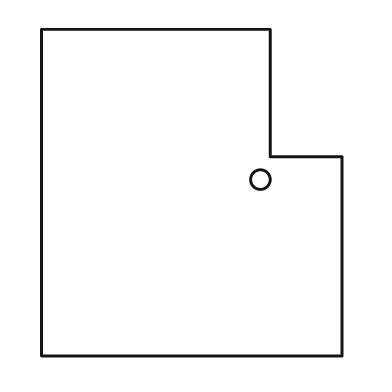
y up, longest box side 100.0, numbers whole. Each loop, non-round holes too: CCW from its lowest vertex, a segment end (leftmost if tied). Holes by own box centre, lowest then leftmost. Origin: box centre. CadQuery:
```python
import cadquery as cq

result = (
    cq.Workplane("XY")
    .moveTo(-46.0, -50.0)
    .lineTo(46.0, -50.0)
    .lineTo(46.0, 11.0)
    .lineTo(24.0, 11.0)
    .lineTo(24.0, 50.0)
    .lineTo(-46.0, 50.0)
    .close()
    .moveTo(21.0, 4.0)
    .circle(3.0)
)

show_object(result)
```